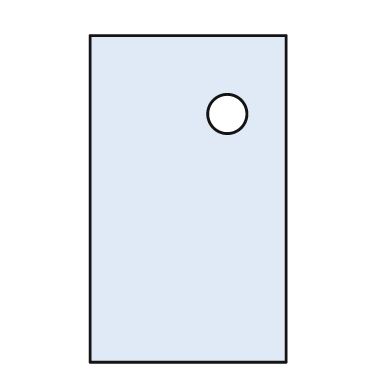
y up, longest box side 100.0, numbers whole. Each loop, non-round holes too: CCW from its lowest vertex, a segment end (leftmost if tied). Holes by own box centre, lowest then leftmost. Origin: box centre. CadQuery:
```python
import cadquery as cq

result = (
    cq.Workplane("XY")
    .moveTo(-30.0, -50.0)
    .lineTo(30.0, -50.0)
    .lineTo(30.0, 50.0)
    .lineTo(-30.0, 50.0)
    .close()
    .moveTo(12.0, 26.0)
    .circle(6.0)
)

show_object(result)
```